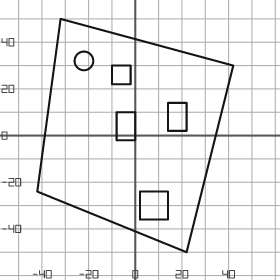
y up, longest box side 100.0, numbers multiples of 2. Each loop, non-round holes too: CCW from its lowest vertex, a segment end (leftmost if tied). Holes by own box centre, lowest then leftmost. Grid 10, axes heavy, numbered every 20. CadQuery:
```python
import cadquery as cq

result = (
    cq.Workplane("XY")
    .moveTo(22.0, -50.0)
    .lineTo(42.0, 30.0)
    .lineTo(-32.0, 50.0)
    .lineTo(-42.0, -24.0)
    .close()
    .moveTo(2.0, -36.0)
    .lineTo(14.0, -36.0)
    .lineTo(14.0, -24.0)
    .lineTo(2.0, -24.0)
    .close()
    .moveTo(-8.0, -2.0)
    .lineTo(0.0, -2.0)
    .lineTo(0.0, 10.0)
    .lineTo(-8.0, 10.0)
    .close()
    .moveTo(14.0, 2.0)
    .lineTo(22.0, 2.0)
    .lineTo(22.0, 14.0)
    .lineTo(14.0, 14.0)
    .close()
    .moveTo(-10.0, 22.0)
    .lineTo(-2.0, 22.0)
    .lineTo(-2.0, 30.0)
    .lineTo(-10.0, 30.0)
    .close()
    .moveTo(-22.0, 32.0)
    .circle(4.0)
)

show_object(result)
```